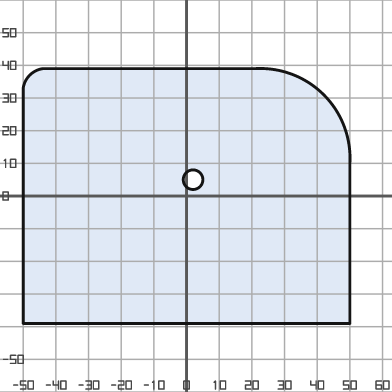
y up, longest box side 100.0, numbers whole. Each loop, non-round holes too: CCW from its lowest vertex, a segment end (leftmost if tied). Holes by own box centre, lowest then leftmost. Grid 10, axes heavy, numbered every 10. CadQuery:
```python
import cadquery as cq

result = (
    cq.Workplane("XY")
    .moveTo(-50.0, -39.0)
    .lineTo(50.0, -39.0)
    .lineTo(50.0, 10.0)
    .threePointArc((42.0, 31.0), (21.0, 39.0))
    .lineTo(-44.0, 39.0)
    .threePointArc((-48.0, 37.0), (-50.0, 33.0))
    .close()
    .moveTo(2.0, 5.0)
    .circle(3.0)
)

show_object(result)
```